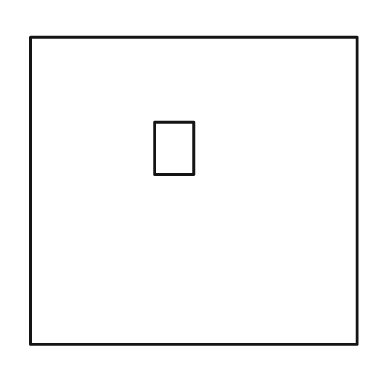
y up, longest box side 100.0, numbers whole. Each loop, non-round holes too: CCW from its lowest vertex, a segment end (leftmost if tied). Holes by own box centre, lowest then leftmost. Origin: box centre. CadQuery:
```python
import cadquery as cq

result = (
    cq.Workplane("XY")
    .moveTo(-50.0, -47.0)
    .lineTo(50.0, -47.0)
    .lineTo(50.0, 47.0)
    .lineTo(-50.0, 47.0)
    .close()
    .moveTo(-12.0, 5.0)
    .lineTo(0.0, 5.0)
    .lineTo(0.0, 21.0)
    .lineTo(-12.0, 21.0)
    .close()
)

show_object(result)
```